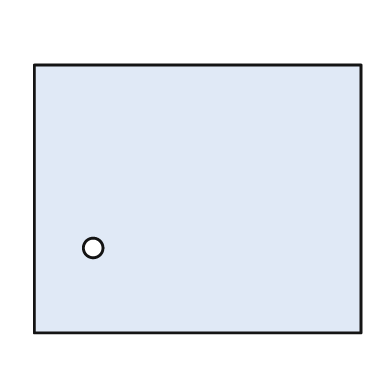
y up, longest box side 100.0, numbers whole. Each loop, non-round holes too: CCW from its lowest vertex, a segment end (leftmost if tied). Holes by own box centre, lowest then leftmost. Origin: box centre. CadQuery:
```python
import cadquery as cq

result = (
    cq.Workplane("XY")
    .moveTo(-50.0, -41.0)
    .lineTo(50.0, -41.0)
    .lineTo(50.0, 41.0)
    .lineTo(-50.0, 41.0)
    .close()
    .moveTo(-32.0, -15.0)
    .circle(3.0)
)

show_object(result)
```